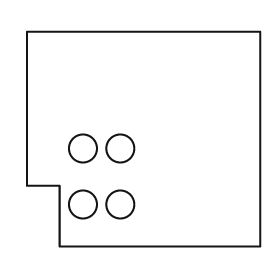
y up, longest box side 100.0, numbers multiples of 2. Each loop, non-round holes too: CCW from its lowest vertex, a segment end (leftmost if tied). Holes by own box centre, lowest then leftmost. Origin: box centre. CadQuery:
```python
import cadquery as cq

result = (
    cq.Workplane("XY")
    .moveTo(-36.0, -46.0)
    .lineTo(50.0, -46.0)
    .lineTo(50.0, 46.0)
    .lineTo(-50.0, 46.0)
    .lineTo(-50.0, -20.0)
    .lineTo(-36.0, -20.0)
    .close()
    .moveTo(-26.0, -28.0)
    .circle(6.0)
    .moveTo(-10.0, -28.0)
    .circle(6.0)
    .moveTo(-26.0, -4.0)
    .circle(6.0)
    .moveTo(-10.0, -4.0)
    .circle(6.0)
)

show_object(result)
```